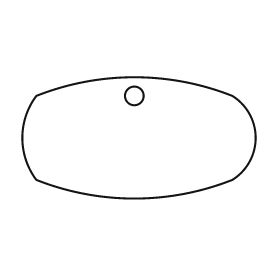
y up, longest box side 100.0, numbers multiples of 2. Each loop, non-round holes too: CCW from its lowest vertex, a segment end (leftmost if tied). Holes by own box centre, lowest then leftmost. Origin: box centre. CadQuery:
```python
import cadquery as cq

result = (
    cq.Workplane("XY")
    .moveTo(-44.0, -18.0)
    .threePointArc((-2.0, -26.0), (40.0, -18.0))
    .threePointArc((50.0, 0.0), (40.0, 18.0))
    .threePointArc((-2.0, 26.0), (-44.0, 18.0))
    .threePointArc((-50.0, 0.0), (-44.0, -18.0))
    .close()
    .moveTo(-2.0, 18.0)
    .circle(4.0)
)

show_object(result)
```